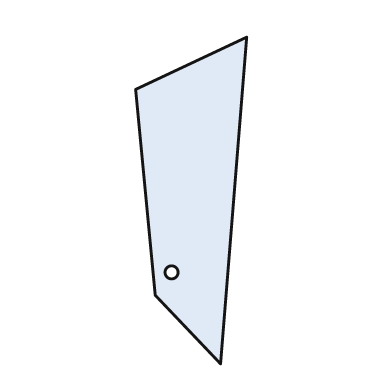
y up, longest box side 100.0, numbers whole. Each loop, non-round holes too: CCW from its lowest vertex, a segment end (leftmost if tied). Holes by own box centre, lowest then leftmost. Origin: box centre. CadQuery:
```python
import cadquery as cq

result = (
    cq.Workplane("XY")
    .moveTo(9.0, -50.0)
    .lineTo(17.0, 50.0)
    .lineTo(-17.0, 34.0)
    .lineTo(-11.0, -29.0)
    .close()
    .moveTo(-6.0, -22.0)
    .circle(2.0)
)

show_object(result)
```